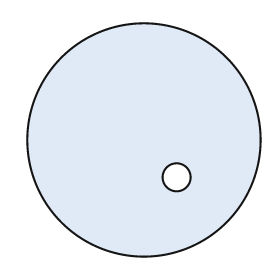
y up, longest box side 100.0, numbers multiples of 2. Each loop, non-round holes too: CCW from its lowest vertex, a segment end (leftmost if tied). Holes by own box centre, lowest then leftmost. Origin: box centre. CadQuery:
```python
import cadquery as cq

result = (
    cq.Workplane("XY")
    .moveTo(0.0, 0.0)
    .circle(50.0)
    .moveTo(14.0, -16.0)
    .circle(6.0)
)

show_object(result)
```